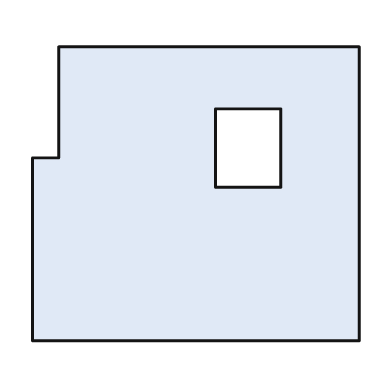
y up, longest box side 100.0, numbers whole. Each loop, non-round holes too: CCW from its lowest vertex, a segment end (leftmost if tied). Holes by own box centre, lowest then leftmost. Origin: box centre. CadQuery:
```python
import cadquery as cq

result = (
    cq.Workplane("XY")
    .moveTo(-50.0, -45.0)
    .lineTo(50.0, -45.0)
    .lineTo(50.0, 45.0)
    .lineTo(-42.0, 45.0)
    .lineTo(-42.0, 11.0)
    .lineTo(-50.0, 11.0)
    .close()
    .moveTo(6.0, 2.0)
    .lineTo(26.0, 2.0)
    .lineTo(26.0, 26.0)
    .lineTo(6.0, 26.0)
    .close()
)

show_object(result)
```